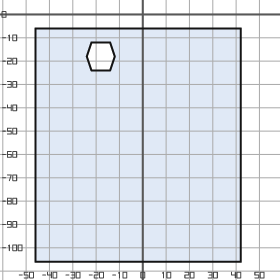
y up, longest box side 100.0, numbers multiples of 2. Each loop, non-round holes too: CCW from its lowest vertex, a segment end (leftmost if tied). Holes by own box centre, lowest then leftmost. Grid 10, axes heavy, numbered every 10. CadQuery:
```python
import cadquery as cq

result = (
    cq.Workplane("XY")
    .moveTo(-46.0, -106.0)
    .lineTo(42.0, -106.0)
    .lineTo(42.0, -6.0)
    .lineTo(-46.0, -6.0)
    .close()
    .moveTo(-22.0, -24.0)
    .lineTo(-14.0, -24.0)
    .lineTo(-12.0, -18.0)
    .lineTo(-14.0, -12.0)
    .lineTo(-22.0, -12.0)
    .lineTo(-24.0, -18.0)
    .close()
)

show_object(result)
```